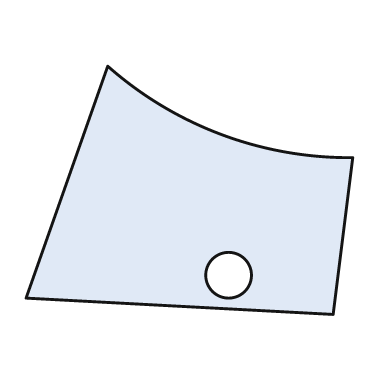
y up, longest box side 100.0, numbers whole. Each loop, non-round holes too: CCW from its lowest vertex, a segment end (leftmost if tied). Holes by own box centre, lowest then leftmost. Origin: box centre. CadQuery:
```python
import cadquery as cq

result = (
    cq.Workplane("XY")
    .moveTo(44.0, -38.0)
    .lineTo(50.0, 10.0)
    .threePointArc((10.0, 17.0), (-25.0, 38.0))
    .lineTo(-50.0, -33.0)
    .close()
    .moveTo(12.0, -26.0)
    .circle(7.0)
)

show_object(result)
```